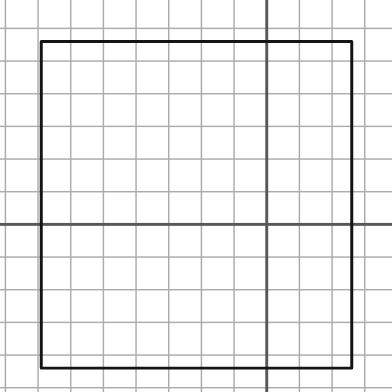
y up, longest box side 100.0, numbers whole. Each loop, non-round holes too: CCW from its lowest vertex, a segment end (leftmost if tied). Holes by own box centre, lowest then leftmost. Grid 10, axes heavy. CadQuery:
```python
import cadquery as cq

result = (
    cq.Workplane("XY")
    .moveTo(-69.0, -44.0)
    .lineTo(26.0, -44.0)
    .lineTo(26.0, 56.0)
    .lineTo(-69.0, 56.0)
    .close()
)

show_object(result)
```